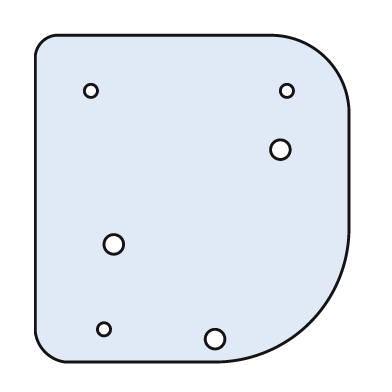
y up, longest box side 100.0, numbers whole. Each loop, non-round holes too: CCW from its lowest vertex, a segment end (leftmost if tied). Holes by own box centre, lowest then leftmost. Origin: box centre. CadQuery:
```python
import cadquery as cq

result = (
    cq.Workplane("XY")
    .moveTo(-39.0, -50.0)
    .lineTo(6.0, -50.0)
    .threePointArc((36.0, -38.0), (48.0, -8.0))
    .lineTo(48.0, 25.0)
    .threePointArc((41.0, 43.0), (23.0, 50.0))
    .lineTo(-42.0, 50.0)
    .threePointArc((-46.0, 48.0), (-48.0, 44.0))
    .lineTo(-48.0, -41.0)
    .threePointArc((-45.0, -47.0), (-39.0, -50.0))
    .close()
    .moveTo(7.0, -43.0)
    .circle(3.0)
    .moveTo(-27.0, -40.0)
    .circle(2.0)
    .moveTo(-24.0, -14.0)
    .circle(3.0)
    .moveTo(27.0, 15.0)
    .circle(3.0)
    .moveTo(-31.0, 33.0)
    .circle(2.0)
    .moveTo(29.0, 33.0)
    .circle(2.0)
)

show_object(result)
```